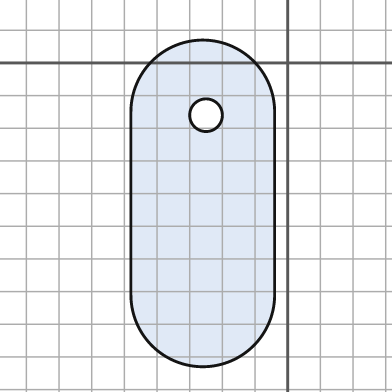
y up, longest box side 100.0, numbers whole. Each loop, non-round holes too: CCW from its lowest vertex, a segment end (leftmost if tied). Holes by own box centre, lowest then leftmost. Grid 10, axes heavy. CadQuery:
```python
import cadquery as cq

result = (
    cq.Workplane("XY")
    .moveTo(-48.0, -71.0)
    .threePointArc((-26.0, -93.0), (-4.0, -71.0))
    .lineTo(-4.0, -15.0)
    .threePointArc((-26.0, 7.0), (-48.0, -15.0))
    .close()
    .moveTo(-25.0, -16.0)
    .circle(5.0)
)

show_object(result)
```